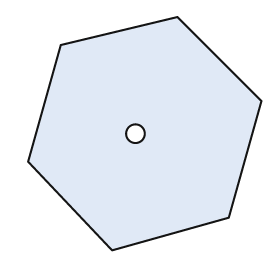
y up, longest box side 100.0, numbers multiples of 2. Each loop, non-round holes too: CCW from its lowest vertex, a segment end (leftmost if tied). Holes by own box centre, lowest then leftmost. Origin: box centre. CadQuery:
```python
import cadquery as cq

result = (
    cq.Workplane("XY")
    .moveTo(-14.0, -50.0)
    .lineTo(36.0, -36.0)
    .lineTo(50.0, 14.0)
    .lineTo(14.0, 50.0)
    .lineTo(-36.0, 38.0)
    .lineTo(-50.0, -12.0)
    .close()
    .moveTo(-4.0, 0.0)
    .circle(4.0)
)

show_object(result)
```